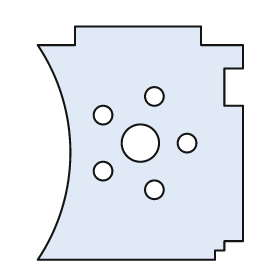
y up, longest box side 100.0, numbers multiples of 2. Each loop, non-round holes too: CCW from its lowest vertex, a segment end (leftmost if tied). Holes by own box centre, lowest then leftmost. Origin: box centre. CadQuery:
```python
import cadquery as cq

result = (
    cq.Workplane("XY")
    .moveTo(-44.0, -50.0)
    .lineTo(32.0, -50.0)
    .lineTo(32.0, -46.0)
    .lineTo(36.0, -46.0)
    .lineTo(36.0, -42.0)
    .lineTo(44.0, -42.0)
    .lineTo(44.0, 16.0)
    .lineTo(36.0, 16.0)
    .lineTo(36.0, 32.0)
    .lineTo(44.0, 32.0)
    .lineTo(44.0, 42.0)
    .lineTo(26.0, 42.0)
    .lineTo(26.0, 50.0)
    .lineTo(-28.0, 50.0)
    .lineTo(-28.0, 42.0)
    .lineTo(-44.0, 42.0)
    .threePointArc((-30.0, -4.0), (-44.0, -50.0))
    .close()
    .moveTo(6.0, -20.0)
    .circle(4.0)
    .moveTo(-16.0, -12.0)
    .circle(4.0)
    .moveTo(0.0, 0.0)
    .circle(8.0)
    .moveTo(20.0, 0.0)
    .circle(4.0)
    .moveTo(-16.0, 12.0)
    .circle(4.0)
    .moveTo(6.0, 20.0)
    .circle(4.0)
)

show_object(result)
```